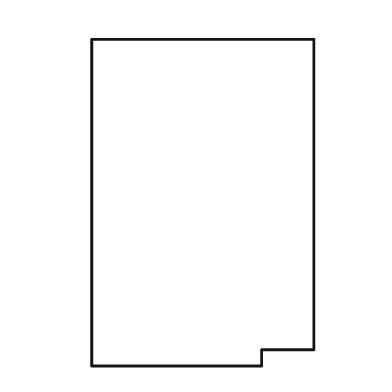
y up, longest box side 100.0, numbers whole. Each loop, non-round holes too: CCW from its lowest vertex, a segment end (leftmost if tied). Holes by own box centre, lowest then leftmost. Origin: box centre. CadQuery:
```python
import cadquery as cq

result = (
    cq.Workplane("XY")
    .moveTo(-34.0, -50.0)
    .lineTo(18.0, -50.0)
    .lineTo(18.0, -45.0)
    .lineTo(34.0, -45.0)
    .lineTo(34.0, 50.0)
    .lineTo(-34.0, 50.0)
    .close()
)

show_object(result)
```